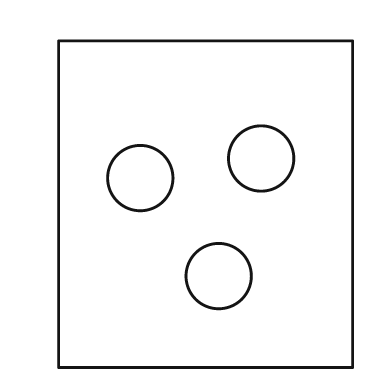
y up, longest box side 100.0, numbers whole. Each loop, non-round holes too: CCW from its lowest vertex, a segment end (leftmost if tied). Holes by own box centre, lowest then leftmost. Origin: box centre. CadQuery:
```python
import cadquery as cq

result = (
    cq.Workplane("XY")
    .moveTo(-45.0, -50.0)
    .lineTo(45.0, -50.0)
    .lineTo(45.0, 50.0)
    .lineTo(-45.0, 50.0)
    .close()
    .moveTo(4.0, -22.0)
    .circle(10.0)
    .moveTo(-20.0, 8.0)
    .circle(10.0)
    .moveTo(17.0, 14.0)
    .circle(10.0)
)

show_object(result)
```